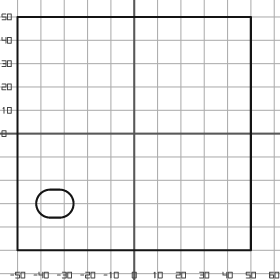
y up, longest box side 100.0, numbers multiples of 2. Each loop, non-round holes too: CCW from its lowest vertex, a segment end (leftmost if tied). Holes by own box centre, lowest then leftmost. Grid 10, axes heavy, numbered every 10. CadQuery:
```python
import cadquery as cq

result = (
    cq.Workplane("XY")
    .moveTo(-50.0, -50.0)
    .lineTo(50.0, -50.0)
    .lineTo(50.0, 50.0)
    .lineTo(-50.0, 50.0)
    .close()
    .moveTo(-36.0, -36.0)
    .lineTo(-32.0, -36.0)
    .threePointArc((-26.0, -30.0), (-32.0, -24.0))
    .lineTo(-36.0, -24.0)
    .threePointArc((-42.0, -30.0), (-36.0, -36.0))
    .close()
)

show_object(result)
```